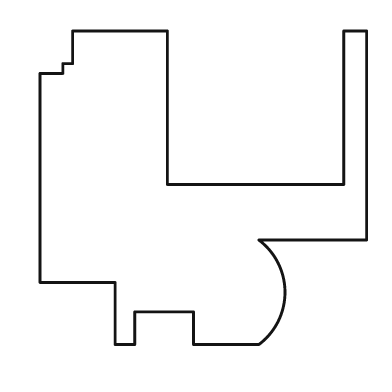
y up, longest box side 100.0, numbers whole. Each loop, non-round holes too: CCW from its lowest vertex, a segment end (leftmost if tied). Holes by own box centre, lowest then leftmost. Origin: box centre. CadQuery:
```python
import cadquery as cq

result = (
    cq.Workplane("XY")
    .moveTo(-27.0, -48.0)
    .lineTo(-21.0, -48.0)
    .lineTo(-21.0, -38.0)
    .lineTo(-3.0, -38.0)
    .lineTo(-3.0, -48.0)
    .lineTo(17.0, -48.0)
    .threePointArc((25.0, -32.0), (17.0, -16.0))
    .lineTo(50.0, -16.0)
    .lineTo(50.0, 48.0)
    .lineTo(43.0, 48.0)
    .lineTo(43.0, 1.0)
    .lineTo(-11.0, 1.0)
    .lineTo(-11.0, 48.0)
    .lineTo(-40.0, 48.0)
    .lineTo(-40.0, 38.0)
    .lineTo(-43.0, 38.0)
    .lineTo(-43.0, 35.0)
    .lineTo(-50.0, 35.0)
    .lineTo(-50.0, -29.0)
    .lineTo(-27.0, -29.0)
    .close()
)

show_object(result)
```